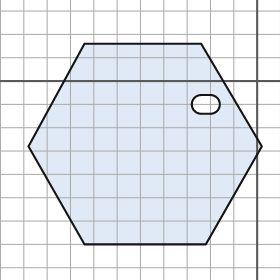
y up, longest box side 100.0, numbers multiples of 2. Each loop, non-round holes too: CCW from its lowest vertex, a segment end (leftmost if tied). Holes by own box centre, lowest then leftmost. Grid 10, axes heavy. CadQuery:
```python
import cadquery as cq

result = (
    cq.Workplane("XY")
    .moveTo(-74.0, -70.0)
    .lineTo(-22.0, -70.0)
    .lineTo(2.0, -28.0)
    .lineTo(-24.0, 16.0)
    .lineTo(-74.0, 16.0)
    .lineTo(-98.0, -28.0)
    .close()
    .moveTo(-24.0, -14.0)
    .lineTo(-20.0, -14.0)
    .threePointArc((-16.0, -10.0), (-20.0, -6.0))
    .lineTo(-24.0, -6.0)
    .threePointArc((-28.0, -10.0), (-24.0, -14.0))
    .close()
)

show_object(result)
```